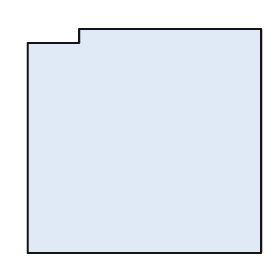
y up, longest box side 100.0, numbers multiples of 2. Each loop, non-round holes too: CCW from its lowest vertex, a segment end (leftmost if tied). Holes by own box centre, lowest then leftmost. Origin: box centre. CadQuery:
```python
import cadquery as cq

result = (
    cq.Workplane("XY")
    .moveTo(-50.0, -48.0)
    .lineTo(50.0, -48.0)
    .lineTo(50.0, 48.0)
    .lineTo(-28.0, 48.0)
    .lineTo(-28.0, 42.0)
    .lineTo(-50.0, 42.0)
    .close()
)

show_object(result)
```